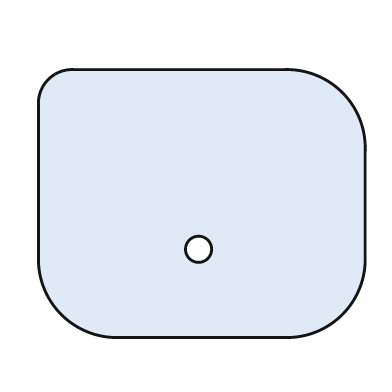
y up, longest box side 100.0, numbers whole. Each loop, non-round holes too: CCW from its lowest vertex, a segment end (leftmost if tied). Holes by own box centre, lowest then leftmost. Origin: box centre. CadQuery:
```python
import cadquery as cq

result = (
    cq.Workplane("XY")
    .moveTo(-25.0, -41.0)
    .lineTo(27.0, -41.0)
    .threePointArc((43.0, -34.0), (50.0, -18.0))
    .lineTo(50.0, 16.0)
    .threePointArc((43.0, 34.0), (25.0, 41.0))
    .lineTo(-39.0, 41.0)
    .threePointArc((-47.0, 38.0), (-50.0, 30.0))
    .lineTo(-50.0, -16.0)
    .threePointArc((-43.0, -34.0), (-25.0, -41.0))
    .close()
    .moveTo(-1.0, -14.0)
    .circle(4.0)
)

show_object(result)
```